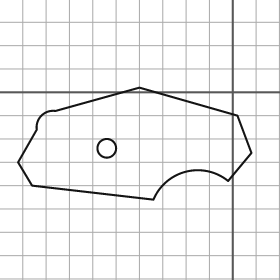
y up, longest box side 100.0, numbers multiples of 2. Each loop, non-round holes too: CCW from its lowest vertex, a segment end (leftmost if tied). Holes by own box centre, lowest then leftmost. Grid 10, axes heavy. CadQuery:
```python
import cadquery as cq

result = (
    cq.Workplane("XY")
    .moveTo(-34.0, -46.0)
    .threePointArc((-20.0, -34.0), (-2.0, -38.0))
    .lineTo(8.0, -26.0)
    .lineTo(2.0, -10.0)
    .lineTo(-40.0, 2.0)
    .lineTo(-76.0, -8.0)
    .threePointArc((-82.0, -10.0), (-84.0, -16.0))
    .lineTo(-92.0, -30.0)
    .lineTo(-86.0, -40.0)
    .close()
    .moveTo(-54.0, -24.0)
    .circle(4.0)
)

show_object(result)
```